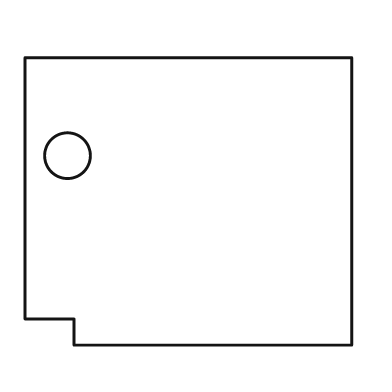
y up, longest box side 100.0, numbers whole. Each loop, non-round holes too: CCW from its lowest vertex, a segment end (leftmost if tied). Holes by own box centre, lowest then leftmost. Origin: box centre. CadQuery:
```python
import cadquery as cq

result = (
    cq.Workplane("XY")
    .moveTo(-35.0, -44.0)
    .lineTo(50.0, -44.0)
    .lineTo(50.0, 44.0)
    .lineTo(-50.0, 44.0)
    .lineTo(-50.0, -36.0)
    .lineTo(-35.0, -36.0)
    .close()
    .moveTo(-37.0, 14.0)
    .circle(7.0)
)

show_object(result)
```